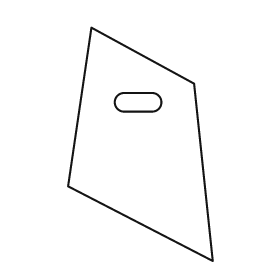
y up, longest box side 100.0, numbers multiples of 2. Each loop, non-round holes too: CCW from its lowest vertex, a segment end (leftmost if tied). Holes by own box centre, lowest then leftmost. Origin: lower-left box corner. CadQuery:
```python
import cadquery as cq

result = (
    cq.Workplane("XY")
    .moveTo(62.0, 0.0)
    .lineTo(54.0, 76.0)
    .lineTo(10.0, 100.0)
    .lineTo(0.0, 32.0)
    .close()
    .moveTo(24.0, 64.0)
    .lineTo(36.0, 64.0)
    .threePointArc((40.0, 68.0), (36.0, 72.0))
    .lineTo(24.0, 72.0)
    .threePointArc((20.0, 68.0), (24.0, 64.0))
    .close()
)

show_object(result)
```